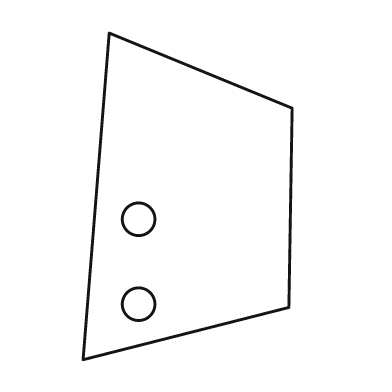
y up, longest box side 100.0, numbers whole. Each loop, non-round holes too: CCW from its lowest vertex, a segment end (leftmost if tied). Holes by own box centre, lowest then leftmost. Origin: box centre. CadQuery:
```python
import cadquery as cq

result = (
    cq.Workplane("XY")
    .moveTo(-32.0, -50.0)
    .lineTo(31.0, -34.0)
    .lineTo(32.0, 27.0)
    .lineTo(-24.0, 50.0)
    .close()
    .moveTo(-15.0, -33.0)
    .circle(5.0)
    .moveTo(-15.0, -7.0)
    .circle(5.0)
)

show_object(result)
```